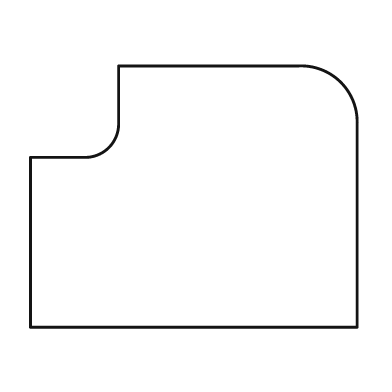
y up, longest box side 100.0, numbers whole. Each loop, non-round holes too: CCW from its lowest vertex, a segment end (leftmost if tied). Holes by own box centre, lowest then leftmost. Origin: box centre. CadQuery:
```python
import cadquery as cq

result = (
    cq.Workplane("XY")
    .moveTo(-50.0, -40.0)
    .lineTo(50.0, -40.0)
    .lineTo(50.0, 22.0)
    .threePointArc((45.0, 35.0), (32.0, 40.0))
    .lineTo(-23.0, 40.0)
    .lineTo(-23.0, 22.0)
    .threePointArc((-26.0, 15.0), (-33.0, 12.0))
    .lineTo(-50.0, 12.0)
    .close()
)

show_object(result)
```